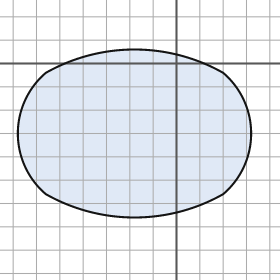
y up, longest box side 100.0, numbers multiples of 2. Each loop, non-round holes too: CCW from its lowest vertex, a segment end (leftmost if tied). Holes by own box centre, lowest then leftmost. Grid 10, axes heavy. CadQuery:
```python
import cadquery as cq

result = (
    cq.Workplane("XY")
    .moveTo(-56.0, -56.0)
    .threePointArc((-18.0, -66.0), (20.0, -56.0))
    .threePointArc((32.0, -30.0), (20.0, -4.0))
    .threePointArc((-18.0, 6.0), (-56.0, -4.0))
    .threePointArc((-68.0, -30.0), (-56.0, -56.0))
    .close()
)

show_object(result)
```